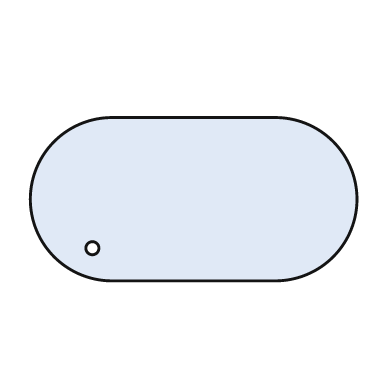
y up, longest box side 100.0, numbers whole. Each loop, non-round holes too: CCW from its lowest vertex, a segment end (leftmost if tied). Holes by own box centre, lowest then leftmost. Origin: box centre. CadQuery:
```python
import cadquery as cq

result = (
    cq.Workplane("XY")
    .moveTo(-25.0, -25.0)
    .lineTo(25.0, -25.0)
    .threePointArc((50.0, 0.0), (25.0, 25.0))
    .lineTo(-25.0, 25.0)
    .threePointArc((-50.0, 0.0), (-25.0, -25.0))
    .close()
    .moveTo(-31.0, -15.0)
    .circle(2.0)
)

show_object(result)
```